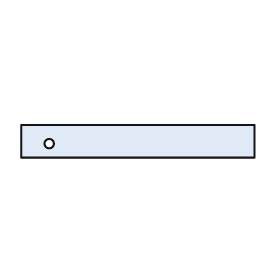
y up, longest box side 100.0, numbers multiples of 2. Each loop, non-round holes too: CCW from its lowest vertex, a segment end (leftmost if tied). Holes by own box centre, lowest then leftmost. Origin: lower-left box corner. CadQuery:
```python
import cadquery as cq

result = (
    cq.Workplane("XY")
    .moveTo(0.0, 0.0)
    .lineTo(100.0, 0.0)
    .lineTo(100.0, 14.0)
    .lineTo(0.0, 14.0)
    .close()
    .moveTo(12.0, 6.0)
    .circle(2.0)
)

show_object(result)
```